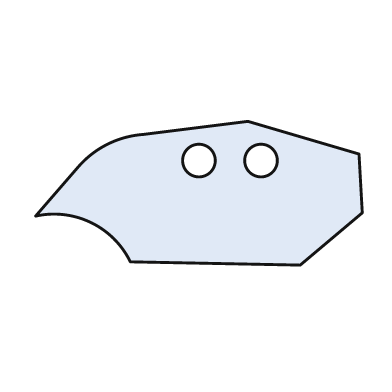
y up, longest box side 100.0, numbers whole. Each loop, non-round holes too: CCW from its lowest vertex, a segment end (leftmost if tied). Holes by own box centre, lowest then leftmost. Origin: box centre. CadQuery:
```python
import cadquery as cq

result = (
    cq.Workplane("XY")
    .moveTo(31.0, -22.0)
    .lineTo(50.0, -6.0)
    .lineTo(49.0, 12.0)
    .lineTo(15.0, 22.0)
    .lineTo(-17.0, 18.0)
    .threePointArc((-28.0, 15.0), (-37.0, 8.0))
    .lineTo(-50.0, -7.0)
    .threePointArc((-33.0, -9.0), (-21.0, -21.0))
    .close()
    .moveTo(0.0, 10.0)
    .circle(5.0)
    .moveTo(19.0, 10.0)
    .circle(5.0)
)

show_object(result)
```